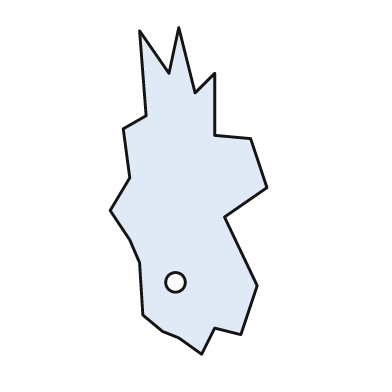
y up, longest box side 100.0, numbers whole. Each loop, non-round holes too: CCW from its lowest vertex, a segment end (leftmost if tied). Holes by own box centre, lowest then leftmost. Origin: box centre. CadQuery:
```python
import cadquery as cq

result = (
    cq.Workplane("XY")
    .moveTo(4.0, -50.0)
    .lineTo(8.0, -42.0)
    .lineTo(16.0, -44.0)
    .lineTo(21.0, -29.0)
    .lineTo(11.0, -8.0)
    .lineTo(24.0, 1.0)
    .lineTo(19.0, 16.0)
    .lineTo(8.0, 17.0)
    .lineTo(8.0, 36.0)
    .lineTo(2.0, 30.0)
    .lineTo(-3.0, 50.0)
    .lineTo(-6.0, 36.0)
    .lineTo(-15.0, 49.0)
    .lineTo(-13.0, 23.0)
    .lineTo(-20.0, 19.0)
    .lineTo(-18.0, 4.0)
    .lineTo(-24.0, -6.0)
    .lineTo(-18.0, -15.0)
    .lineTo(-15.0, -22.0)
    .lineTo(-14.0, -38.0)
    .lineTo(-8.0, -43.0)
    .lineTo(-3.0, -45.0)
    .close()
    .moveTo(-4.0, -28.0)
    .circle(3.0)
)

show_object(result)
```